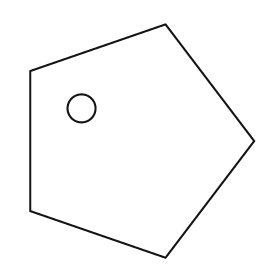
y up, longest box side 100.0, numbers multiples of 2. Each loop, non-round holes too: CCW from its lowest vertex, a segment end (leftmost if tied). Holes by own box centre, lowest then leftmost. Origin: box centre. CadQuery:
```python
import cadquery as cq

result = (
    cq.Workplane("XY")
    .moveTo(10.0, -50.0)
    .lineTo(48.0, 0.0)
    .lineTo(10.0, 50.0)
    .lineTo(-48.0, 30.0)
    .lineTo(-48.0, -30.0)
    .close()
    .moveTo(-26.0, 14.0)
    .circle(6.0)
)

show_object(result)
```